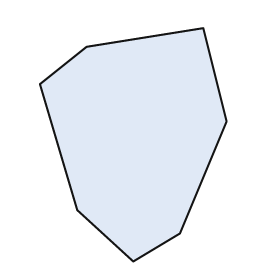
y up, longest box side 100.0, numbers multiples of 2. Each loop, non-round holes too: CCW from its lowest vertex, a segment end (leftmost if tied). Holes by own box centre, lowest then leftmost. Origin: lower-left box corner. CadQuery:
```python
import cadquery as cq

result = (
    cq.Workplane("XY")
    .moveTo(40.0, 0.0)
    .lineTo(60.0, 12.0)
    .lineTo(80.0, 60.0)
    .lineTo(70.0, 100.0)
    .lineTo(20.0, 92.0)
    .lineTo(0.0, 76.0)
    .lineTo(16.0, 22.0)
    .close()
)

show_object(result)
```